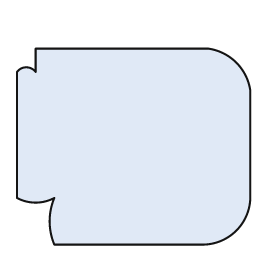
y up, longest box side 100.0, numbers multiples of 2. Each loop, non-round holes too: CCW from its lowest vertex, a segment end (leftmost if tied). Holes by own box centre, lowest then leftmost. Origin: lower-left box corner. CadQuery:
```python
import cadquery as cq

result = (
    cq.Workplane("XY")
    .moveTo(16.0, 0.0)
    .lineTo(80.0, 0.0)
    .threePointArc((94.0, 6.0), (100.0, 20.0))
    .lineTo(100.0, 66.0)
    .threePointArc((94.0, 78.0), (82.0, 84.0))
    .lineTo(8.0, 84.0)
    .lineTo(8.0, 74.0)
    .threePointArc((4.0, 76.0), (0.0, 74.0))
    .lineTo(0.0, 20.0)
    .threePointArc((8.0, 18.0), (16.0, 20.0))
    .threePointArc((14.0, 10.0), (16.0, 0.0))
    .close()
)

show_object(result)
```